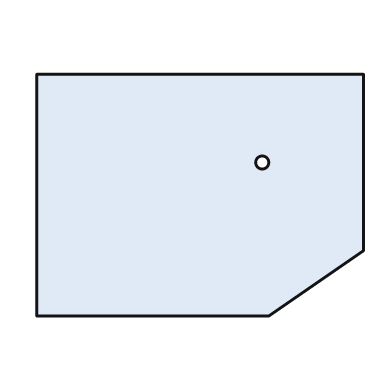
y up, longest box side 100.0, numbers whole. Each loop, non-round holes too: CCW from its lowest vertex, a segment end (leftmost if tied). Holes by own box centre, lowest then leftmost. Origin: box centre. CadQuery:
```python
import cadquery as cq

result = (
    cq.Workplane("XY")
    .moveTo(-50.0, -37.0)
    .lineTo(21.0, -37.0)
    .lineTo(50.0, -17.0)
    .lineTo(50.0, 37.0)
    .lineTo(-50.0, 37.0)
    .close()
    .moveTo(19.0, 10.0)
    .circle(2.0)
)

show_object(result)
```